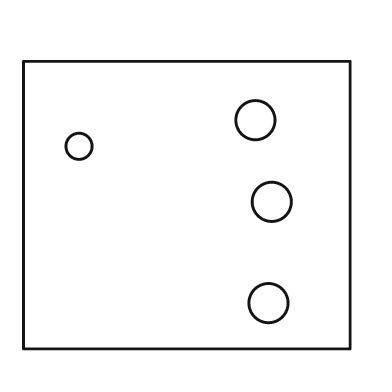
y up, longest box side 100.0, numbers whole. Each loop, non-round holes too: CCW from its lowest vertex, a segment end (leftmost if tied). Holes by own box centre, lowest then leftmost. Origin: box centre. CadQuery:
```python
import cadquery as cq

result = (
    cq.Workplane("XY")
    .moveTo(-50.0, -44.0)
    .lineTo(50.0, -44.0)
    .lineTo(50.0, 44.0)
    .lineTo(-50.0, 44.0)
    .close()
    .moveTo(25.0, -30.0)
    .circle(6.0)
    .moveTo(26.0, 1.0)
    .circle(6.0)
    .moveTo(-33.0, 18.0)
    .circle(4.0)
    .moveTo(21.0, 26.0)
    .circle(6.0)
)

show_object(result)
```